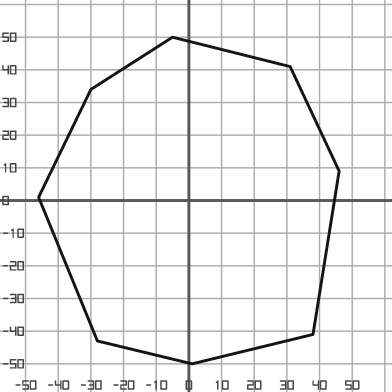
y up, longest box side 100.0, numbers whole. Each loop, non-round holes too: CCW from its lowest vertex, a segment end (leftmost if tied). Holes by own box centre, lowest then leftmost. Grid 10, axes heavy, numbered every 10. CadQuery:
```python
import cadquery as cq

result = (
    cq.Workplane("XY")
    .moveTo(1.0, -50.0)
    .lineTo(38.0, -41.0)
    .lineTo(46.0, 9.0)
    .lineTo(31.0, 41.0)
    .lineTo(-5.0, 50.0)
    .lineTo(-30.0, 34.0)
    .lineTo(-46.0, 1.0)
    .lineTo(-28.0, -43.0)
    .close()
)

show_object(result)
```